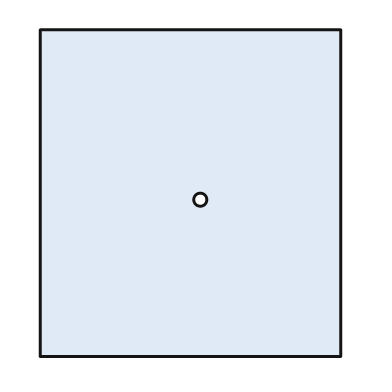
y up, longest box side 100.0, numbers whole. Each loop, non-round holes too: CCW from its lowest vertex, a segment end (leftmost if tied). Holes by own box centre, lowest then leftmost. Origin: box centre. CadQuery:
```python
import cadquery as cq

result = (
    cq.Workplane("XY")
    .moveTo(-46.0, -50.0)
    .lineTo(46.0, -50.0)
    .lineTo(46.0, 50.0)
    .lineTo(-46.0, 50.0)
    .close()
    .moveTo(3.0, -2.0)
    .circle(2.0)
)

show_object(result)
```